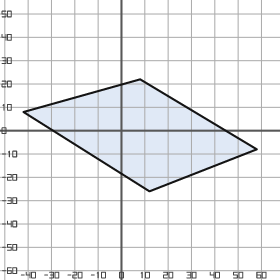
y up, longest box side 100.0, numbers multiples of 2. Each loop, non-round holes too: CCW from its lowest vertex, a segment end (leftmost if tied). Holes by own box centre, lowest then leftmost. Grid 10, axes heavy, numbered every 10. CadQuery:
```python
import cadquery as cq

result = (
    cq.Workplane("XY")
    .moveTo(12.0, -26.0)
    .lineTo(58.0, -8.0)
    .lineTo(8.0, 22.0)
    .lineTo(-42.0, 8.0)
    .close()
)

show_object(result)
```